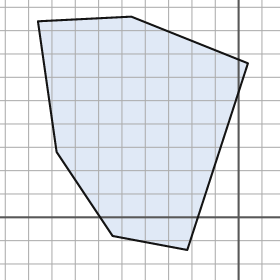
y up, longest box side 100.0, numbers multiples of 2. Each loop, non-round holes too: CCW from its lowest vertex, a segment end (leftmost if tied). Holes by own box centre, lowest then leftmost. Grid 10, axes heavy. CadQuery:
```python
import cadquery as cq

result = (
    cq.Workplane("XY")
    .moveTo(-22.0, -14.0)
    .lineTo(4.0, 66.0)
    .lineTo(-46.0, 86.0)
    .lineTo(-86.0, 84.0)
    .lineTo(-78.0, 28.0)
    .lineTo(-54.0, -8.0)
    .close()
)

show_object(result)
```